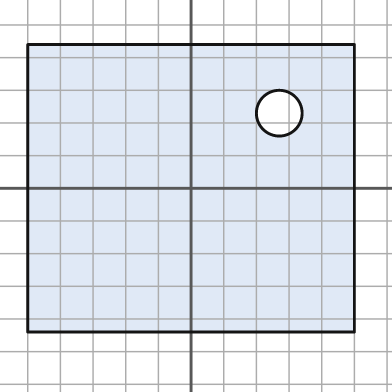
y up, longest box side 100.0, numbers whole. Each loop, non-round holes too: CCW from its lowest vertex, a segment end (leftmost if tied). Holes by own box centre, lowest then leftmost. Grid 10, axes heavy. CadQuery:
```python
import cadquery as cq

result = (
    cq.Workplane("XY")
    .moveTo(-50.0, -44.0)
    .lineTo(50.0, -44.0)
    .lineTo(50.0, 44.0)
    .lineTo(-50.0, 44.0)
    .close()
    .moveTo(27.0, 23.0)
    .circle(7.0)
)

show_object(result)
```